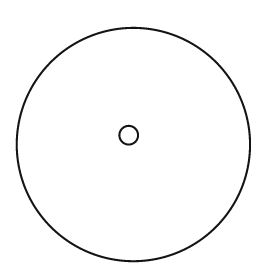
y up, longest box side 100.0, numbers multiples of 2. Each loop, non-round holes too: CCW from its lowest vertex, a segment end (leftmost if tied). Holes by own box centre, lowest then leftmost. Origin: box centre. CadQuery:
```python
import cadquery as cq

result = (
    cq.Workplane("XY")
    .moveTo(0.0, 0.0)
    .circle(50.0)
    .moveTo(-2.0, 4.0)
    .circle(4.0)
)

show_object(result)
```